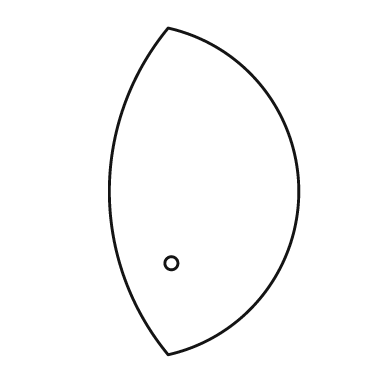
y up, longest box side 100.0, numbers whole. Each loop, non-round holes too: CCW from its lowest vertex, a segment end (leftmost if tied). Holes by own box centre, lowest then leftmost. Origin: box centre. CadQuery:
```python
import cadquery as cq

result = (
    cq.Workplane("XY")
    .moveTo(-11.0, -50.0)
    .threePointArc((29.0, 0.0), (-11.0, 50.0))
    .threePointArc((-29.0, 0.0), (-11.0, -50.0))
    .close()
    .moveTo(-10.0, -22.0)
    .circle(2.0)
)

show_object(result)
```